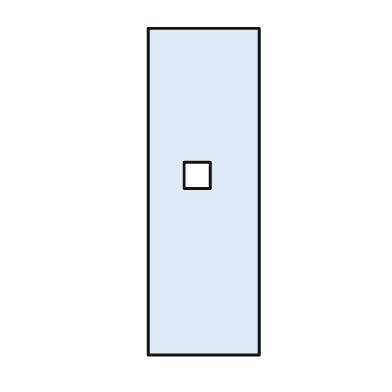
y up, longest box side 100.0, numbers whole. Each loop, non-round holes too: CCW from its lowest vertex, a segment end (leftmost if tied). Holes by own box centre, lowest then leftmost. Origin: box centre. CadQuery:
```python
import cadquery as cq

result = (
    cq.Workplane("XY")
    .moveTo(-17.0, -50.0)
    .lineTo(17.0, -50.0)
    .lineTo(17.0, 50.0)
    .lineTo(-17.0, 50.0)
    .close()
    .moveTo(-6.0, 1.0)
    .lineTo(2.0, 1.0)
    .lineTo(2.0, 9.0)
    .lineTo(-6.0, 9.0)
    .close()
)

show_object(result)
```